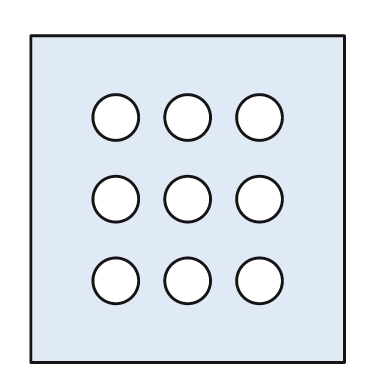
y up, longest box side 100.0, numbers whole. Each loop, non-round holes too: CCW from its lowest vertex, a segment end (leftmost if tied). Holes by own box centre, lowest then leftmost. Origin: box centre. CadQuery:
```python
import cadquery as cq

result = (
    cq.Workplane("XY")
    .moveTo(-48.0, -50.0)
    .lineTo(48.0, -50.0)
    .lineTo(48.0, 50.0)
    .lineTo(-48.0, 50.0)
    .close()
    .moveTo(-22.0, -25.0)
    .circle(7.0)
    .moveTo(0.0, -25.0)
    .circle(7.0)
    .moveTo(22.0, -25.0)
    .circle(7.0)
    .moveTo(-22.0, 0.0)
    .circle(7.0)
    .moveTo(0.0, 0.0)
    .circle(7.0)
    .moveTo(22.0, 0.0)
    .circle(7.0)
    .moveTo(-22.0, 25.0)
    .circle(7.0)
    .moveTo(0.0, 25.0)
    .circle(7.0)
    .moveTo(22.0, 25.0)
    .circle(7.0)
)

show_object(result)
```